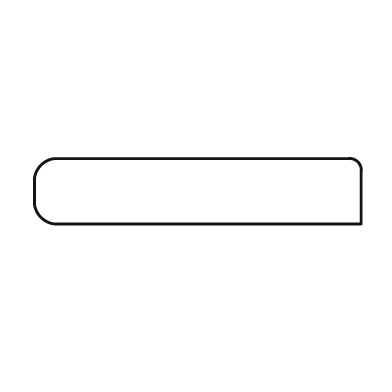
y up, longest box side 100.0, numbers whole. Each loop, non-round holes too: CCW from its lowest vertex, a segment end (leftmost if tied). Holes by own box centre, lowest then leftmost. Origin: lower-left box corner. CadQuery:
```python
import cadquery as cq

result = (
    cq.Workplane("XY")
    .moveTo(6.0, 0.0)
    .lineTo(100.0, 0.0)
    .lineTo(100.0, 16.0)
    .threePointArc((99.0, 19.0), (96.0, 20.0))
    .lineTo(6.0, 20.0)
    .threePointArc((2.0, 18.0), (0.0, 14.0))
    .lineTo(0.0, 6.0)
    .threePointArc((2.0, 2.0), (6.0, 0.0))
    .close()
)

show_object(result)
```